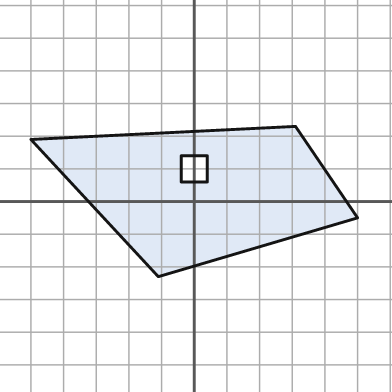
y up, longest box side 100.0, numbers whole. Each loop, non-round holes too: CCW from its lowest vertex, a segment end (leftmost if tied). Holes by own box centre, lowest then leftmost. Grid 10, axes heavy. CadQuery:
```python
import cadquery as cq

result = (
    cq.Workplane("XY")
    .moveTo(-11.0, -23.0)
    .lineTo(50.0, -5.0)
    .lineTo(31.0, 23.0)
    .lineTo(-50.0, 19.0)
    .close()
    .moveTo(-4.0, 6.0)
    .lineTo(4.0, 6.0)
    .lineTo(4.0, 14.0)
    .lineTo(-4.0, 14.0)
    .close()
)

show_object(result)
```